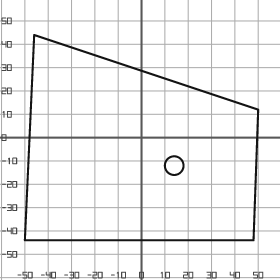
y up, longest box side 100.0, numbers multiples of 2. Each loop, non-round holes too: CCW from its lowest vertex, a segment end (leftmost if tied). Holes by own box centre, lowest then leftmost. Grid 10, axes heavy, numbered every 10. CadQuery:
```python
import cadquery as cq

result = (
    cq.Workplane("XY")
    .moveTo(-50.0, -44.0)
    .lineTo(48.0, -44.0)
    .lineTo(50.0, 12.0)
    .lineTo(-46.0, 44.0)
    .close()
    .moveTo(14.0, -12.0)
    .circle(4.0)
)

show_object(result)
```